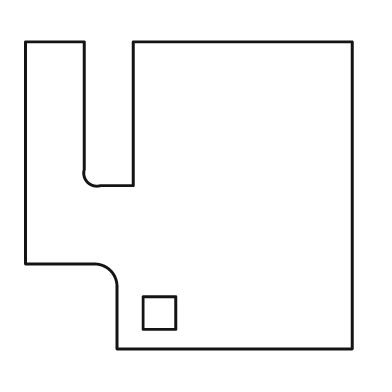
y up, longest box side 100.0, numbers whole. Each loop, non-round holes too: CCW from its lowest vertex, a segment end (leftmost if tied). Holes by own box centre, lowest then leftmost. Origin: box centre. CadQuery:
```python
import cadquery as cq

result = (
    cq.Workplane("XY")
    .moveTo(-22.0, -47.0)
    .lineTo(50.0, -47.0)
    .lineTo(50.0, 47.0)
    .lineTo(-17.0, 47.0)
    .lineTo(-17.0, 3.0)
    .lineTo(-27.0, 3.0)
    .threePointArc((-31.0, 4.0), (-32.0, 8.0))
    .lineTo(-32.0, 47.0)
    .lineTo(-50.0, 47.0)
    .lineTo(-50.0, -21.0)
    .lineTo(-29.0, -21.0)
    .threePointArc((-24.0, -23.0), (-22.0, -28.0))
    .close()
    .moveTo(-14.0, -41.0)
    .lineTo(-4.0, -41.0)
    .lineTo(-4.0, -31.0)
    .lineTo(-14.0, -31.0)
    .close()
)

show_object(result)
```